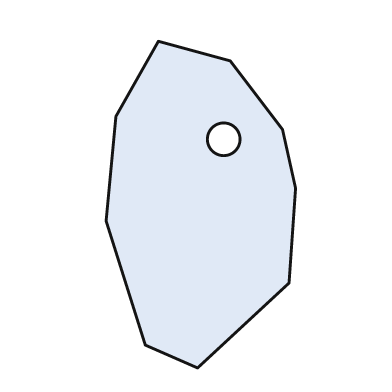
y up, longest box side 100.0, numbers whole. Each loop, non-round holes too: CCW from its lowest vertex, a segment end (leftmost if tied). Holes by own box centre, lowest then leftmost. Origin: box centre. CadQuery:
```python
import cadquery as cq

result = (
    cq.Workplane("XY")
    .moveTo(-1.0, -50.0)
    .lineTo(27.0, -24.0)
    .lineTo(29.0, 5.0)
    .lineTo(25.0, 23.0)
    .lineTo(9.0, 44.0)
    .lineTo(-13.0, 50.0)
    .lineTo(-26.0, 27.0)
    .lineTo(-29.0, -5.0)
    .lineTo(-17.0, -43.0)
    .close()
    .moveTo(7.0, 20.0)
    .circle(5.0)
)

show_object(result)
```